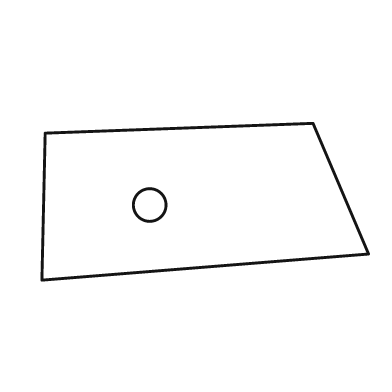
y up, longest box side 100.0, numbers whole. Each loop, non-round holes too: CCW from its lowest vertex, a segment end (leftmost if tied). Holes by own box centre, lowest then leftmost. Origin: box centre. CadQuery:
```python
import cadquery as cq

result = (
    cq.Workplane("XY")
    .moveTo(-50.0, -24.0)
    .lineTo(50.0, -16.0)
    .lineTo(33.0, 24.0)
    .lineTo(-49.0, 21.0)
    .close()
    .moveTo(-17.0, -1.0)
    .circle(5.0)
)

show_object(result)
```